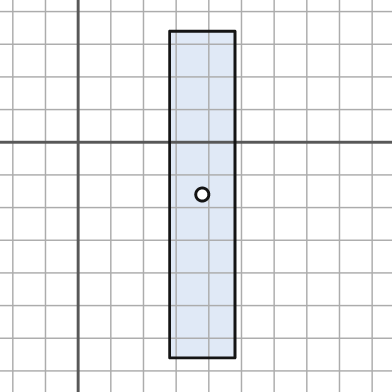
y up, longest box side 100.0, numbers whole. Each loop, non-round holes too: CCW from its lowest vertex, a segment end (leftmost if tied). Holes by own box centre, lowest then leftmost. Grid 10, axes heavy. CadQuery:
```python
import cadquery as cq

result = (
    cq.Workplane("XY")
    .moveTo(28.0, -66.0)
    .lineTo(48.0, -66.0)
    .lineTo(48.0, 34.0)
    .lineTo(28.0, 34.0)
    .close()
    .moveTo(38.0, -16.0)
    .circle(2.0)
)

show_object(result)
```